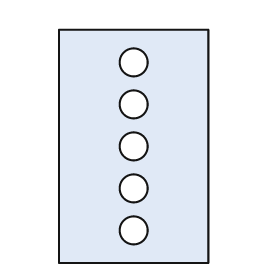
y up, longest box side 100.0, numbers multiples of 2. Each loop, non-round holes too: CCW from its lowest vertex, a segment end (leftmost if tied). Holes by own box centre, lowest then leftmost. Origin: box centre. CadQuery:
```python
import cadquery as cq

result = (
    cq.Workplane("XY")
    .moveTo(-32.0, -50.0)
    .lineTo(32.0, -50.0)
    .lineTo(32.0, 50.0)
    .lineTo(-32.0, 50.0)
    .close()
    .moveTo(0.0, -36.0)
    .circle(6.0)
    .moveTo(0.0, -18.0)
    .circle(6.0)
    .moveTo(0.0, 0.0)
    .circle(6.0)
    .moveTo(0.0, 18.0)
    .circle(6.0)
    .moveTo(0.0, 36.0)
    .circle(6.0)
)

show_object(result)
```